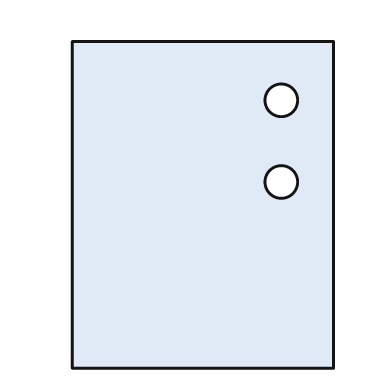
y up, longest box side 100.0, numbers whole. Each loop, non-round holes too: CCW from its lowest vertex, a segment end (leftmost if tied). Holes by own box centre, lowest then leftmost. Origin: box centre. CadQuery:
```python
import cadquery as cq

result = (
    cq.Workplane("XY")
    .moveTo(-40.0, -50.0)
    .lineTo(40.0, -50.0)
    .lineTo(40.0, 50.0)
    .lineTo(-40.0, 50.0)
    .close()
    .moveTo(24.0, 7.0)
    .circle(5.0)
    .moveTo(24.0, 32.0)
    .circle(5.0)
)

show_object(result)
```